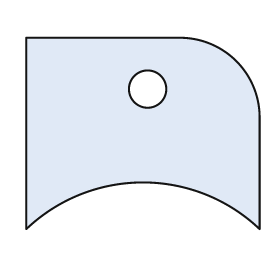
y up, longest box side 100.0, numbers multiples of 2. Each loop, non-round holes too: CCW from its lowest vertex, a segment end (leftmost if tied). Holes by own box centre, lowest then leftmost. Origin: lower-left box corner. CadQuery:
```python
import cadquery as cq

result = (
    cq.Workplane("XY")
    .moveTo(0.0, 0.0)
    .threePointArc((50.0, 20.0), (100.0, 0.0))
    .lineTo(100.0, 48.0)
    .threePointArc((90.0, 72.0), (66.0, 82.0))
    .lineTo(0.0, 82.0)
    .close()
    .moveTo(52.0, 60.0)
    .circle(8.0)
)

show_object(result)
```